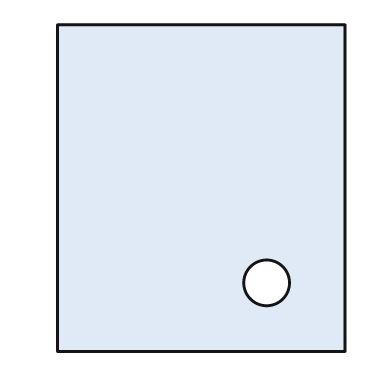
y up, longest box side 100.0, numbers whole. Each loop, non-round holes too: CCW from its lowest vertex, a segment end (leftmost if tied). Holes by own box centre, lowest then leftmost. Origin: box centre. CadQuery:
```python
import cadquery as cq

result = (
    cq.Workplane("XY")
    .moveTo(-44.0, -50.0)
    .lineTo(44.0, -50.0)
    .lineTo(44.0, 50.0)
    .lineTo(-44.0, 50.0)
    .close()
    .moveTo(20.0, -29.0)
    .circle(7.0)
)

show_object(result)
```